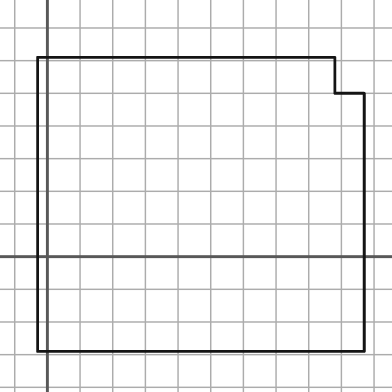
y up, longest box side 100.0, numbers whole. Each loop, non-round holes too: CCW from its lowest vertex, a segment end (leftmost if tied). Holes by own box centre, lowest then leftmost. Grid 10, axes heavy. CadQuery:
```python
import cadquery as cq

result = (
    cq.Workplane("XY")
    .moveTo(-3.0, -29.0)
    .lineTo(97.0, -29.0)
    .lineTo(97.0, 50.0)
    .lineTo(88.0, 50.0)
    .lineTo(88.0, 61.0)
    .lineTo(-3.0, 61.0)
    .close()
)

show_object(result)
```